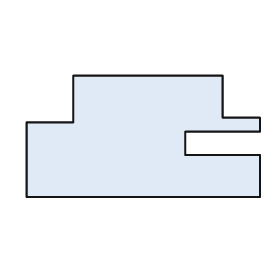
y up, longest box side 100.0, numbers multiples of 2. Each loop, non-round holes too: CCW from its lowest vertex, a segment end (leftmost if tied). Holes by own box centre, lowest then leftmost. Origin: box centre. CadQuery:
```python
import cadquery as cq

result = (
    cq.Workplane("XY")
    .moveTo(-50.0, -26.0)
    .lineTo(50.0, -26.0)
    .lineTo(50.0, -8.0)
    .lineTo(18.0, -8.0)
    .lineTo(18.0, 2.0)
    .lineTo(50.0, 2.0)
    .lineTo(50.0, 8.0)
    .lineTo(34.0, 8.0)
    .lineTo(34.0, 26.0)
    .lineTo(-30.0, 26.0)
    .lineTo(-30.0, 6.0)
    .lineTo(-50.0, 6.0)
    .close()
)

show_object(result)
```